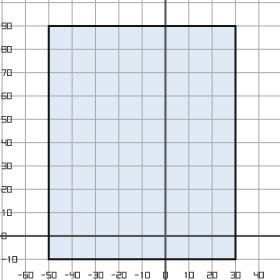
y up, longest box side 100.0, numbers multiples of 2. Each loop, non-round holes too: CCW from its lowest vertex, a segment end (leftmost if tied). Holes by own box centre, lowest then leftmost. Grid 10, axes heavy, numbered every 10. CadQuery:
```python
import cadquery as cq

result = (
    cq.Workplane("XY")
    .moveTo(-50.0, -10.0)
    .lineTo(30.0, -10.0)
    .lineTo(30.0, 90.0)
    .lineTo(-50.0, 90.0)
    .close()
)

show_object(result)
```